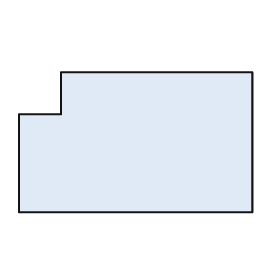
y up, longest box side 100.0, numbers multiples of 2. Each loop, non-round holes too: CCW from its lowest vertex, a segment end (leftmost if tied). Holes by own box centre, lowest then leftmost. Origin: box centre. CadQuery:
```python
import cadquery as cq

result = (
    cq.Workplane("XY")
    .moveTo(-50.0, -30.0)
    .lineTo(50.0, -30.0)
    .lineTo(50.0, 30.0)
    .lineTo(-32.0, 30.0)
    .lineTo(-32.0, 12.0)
    .lineTo(-50.0, 12.0)
    .close()
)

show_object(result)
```